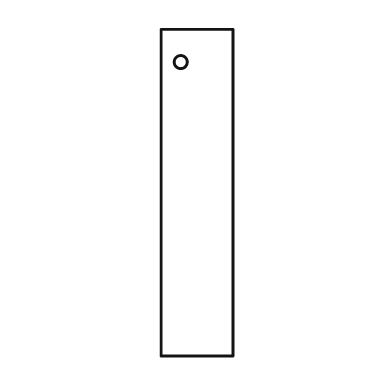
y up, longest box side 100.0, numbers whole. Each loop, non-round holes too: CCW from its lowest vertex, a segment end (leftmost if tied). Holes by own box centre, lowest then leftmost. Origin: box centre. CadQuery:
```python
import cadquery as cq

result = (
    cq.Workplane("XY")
    .moveTo(-11.0, -50.0)
    .lineTo(11.0, -50.0)
    .lineTo(11.0, 50.0)
    .lineTo(-11.0, 50.0)
    .close()
    .moveTo(-5.0, 40.0)
    .circle(2.0)
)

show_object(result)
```